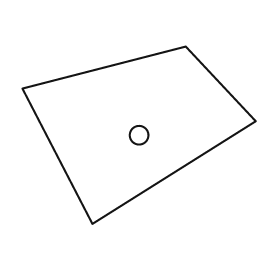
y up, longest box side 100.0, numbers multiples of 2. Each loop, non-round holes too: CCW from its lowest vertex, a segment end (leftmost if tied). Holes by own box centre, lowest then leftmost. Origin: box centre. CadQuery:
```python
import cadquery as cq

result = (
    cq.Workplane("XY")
    .moveTo(-20.0, -38.0)
    .lineTo(50.0, 6.0)
    .lineTo(20.0, 38.0)
    .lineTo(-50.0, 20.0)
    .close()
    .moveTo(0.0, 0.0)
    .circle(4.0)
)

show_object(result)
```